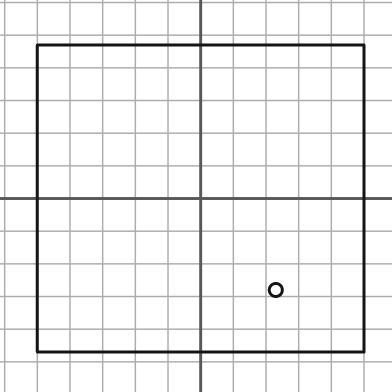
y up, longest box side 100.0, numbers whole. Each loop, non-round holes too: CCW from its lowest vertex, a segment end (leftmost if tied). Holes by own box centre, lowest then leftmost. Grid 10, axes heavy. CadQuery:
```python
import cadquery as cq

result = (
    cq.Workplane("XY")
    .moveTo(-50.0, -47.0)
    .lineTo(50.0, -47.0)
    .lineTo(50.0, 47.0)
    .lineTo(-50.0, 47.0)
    .close()
    .moveTo(23.0, -28.0)
    .circle(2.0)
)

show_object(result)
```